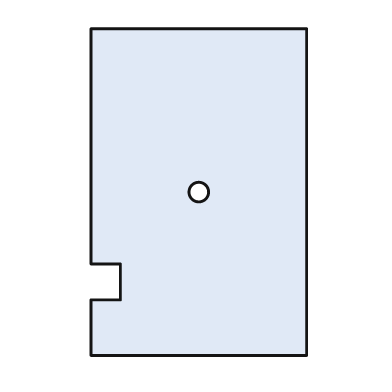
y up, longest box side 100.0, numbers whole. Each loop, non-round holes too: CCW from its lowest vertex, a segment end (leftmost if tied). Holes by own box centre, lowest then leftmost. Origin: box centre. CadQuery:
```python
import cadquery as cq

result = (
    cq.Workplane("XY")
    .moveTo(-33.0, -50.0)
    .lineTo(33.0, -50.0)
    .lineTo(33.0, 50.0)
    .lineTo(-33.0, 50.0)
    .lineTo(-33.0, -22.0)
    .lineTo(-24.0, -22.0)
    .lineTo(-24.0, -33.0)
    .lineTo(-33.0, -33.0)
    .close()
    .moveTo(0.0, 0.0)
    .circle(3.0)
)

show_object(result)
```